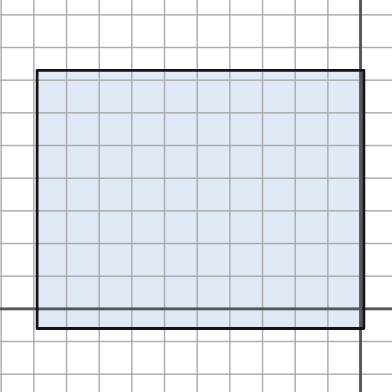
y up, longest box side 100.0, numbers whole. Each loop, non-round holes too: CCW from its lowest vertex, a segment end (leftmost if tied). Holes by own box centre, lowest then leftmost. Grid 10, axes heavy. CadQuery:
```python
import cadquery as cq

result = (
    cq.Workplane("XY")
    .moveTo(-99.0, -6.0)
    .lineTo(1.0, -6.0)
    .lineTo(1.0, 73.0)
    .lineTo(-99.0, 73.0)
    .close()
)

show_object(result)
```